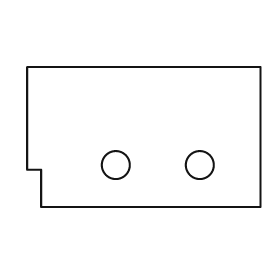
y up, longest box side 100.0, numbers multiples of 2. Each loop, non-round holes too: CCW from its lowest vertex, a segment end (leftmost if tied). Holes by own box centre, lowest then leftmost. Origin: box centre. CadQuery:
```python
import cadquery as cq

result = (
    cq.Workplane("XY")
    .moveTo(-44.0, -30.0)
    .lineTo(50.0, -30.0)
    .lineTo(50.0, 30.0)
    .lineTo(-50.0, 30.0)
    .lineTo(-50.0, -14.0)
    .lineTo(-44.0, -14.0)
    .close()
    .moveTo(-12.0, -12.0)
    .circle(6.0)
    .moveTo(24.0, -12.0)
    .circle(6.0)
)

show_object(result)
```